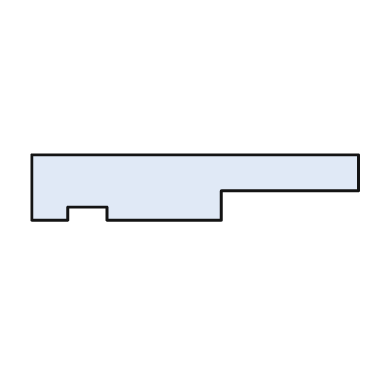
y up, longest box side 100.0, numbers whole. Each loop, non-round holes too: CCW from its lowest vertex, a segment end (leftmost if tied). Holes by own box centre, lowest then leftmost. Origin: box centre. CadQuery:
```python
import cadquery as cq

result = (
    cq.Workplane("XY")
    .moveTo(-50.0, -10.0)
    .lineTo(-39.0, -10.0)
    .lineTo(-39.0, -6.0)
    .lineTo(-27.0, -6.0)
    .lineTo(-27.0, -10.0)
    .lineTo(8.0, -10.0)
    .lineTo(8.0, -1.0)
    .lineTo(50.0, -1.0)
    .lineTo(50.0, 10.0)
    .lineTo(-50.0, 10.0)
    .close()
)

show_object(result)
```